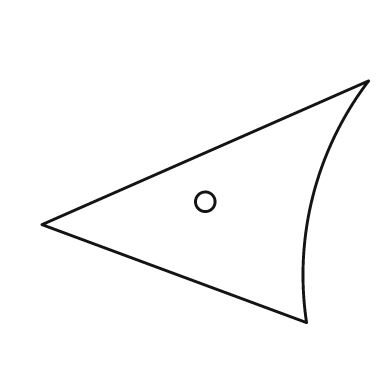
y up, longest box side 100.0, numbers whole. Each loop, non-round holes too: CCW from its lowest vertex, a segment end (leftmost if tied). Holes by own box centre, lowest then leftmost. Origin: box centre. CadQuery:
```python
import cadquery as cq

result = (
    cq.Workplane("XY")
    .moveTo(31.0, -37.0)
    .threePointArc((33.0, 2.0), (50.0, 37.0))
    .lineTo(-50.0, -7.0)
    .close()
    .moveTo(0.0, 0.0)
    .circle(3.0)
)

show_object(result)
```